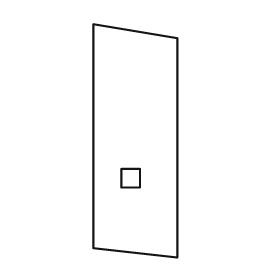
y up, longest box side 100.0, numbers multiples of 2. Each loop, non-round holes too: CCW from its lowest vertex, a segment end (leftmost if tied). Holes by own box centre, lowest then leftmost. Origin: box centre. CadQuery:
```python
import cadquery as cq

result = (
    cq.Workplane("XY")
    .moveTo(18.0, -50.0)
    .lineTo(18.0, 44.0)
    .lineTo(-18.0, 50.0)
    .lineTo(-18.0, -46.0)
    .close()
    .moveTo(-6.0, -20.0)
    .lineTo(2.0, -20.0)
    .lineTo(2.0, -12.0)
    .lineTo(-6.0, -12.0)
    .close()
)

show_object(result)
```